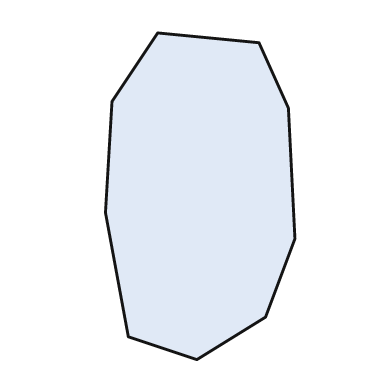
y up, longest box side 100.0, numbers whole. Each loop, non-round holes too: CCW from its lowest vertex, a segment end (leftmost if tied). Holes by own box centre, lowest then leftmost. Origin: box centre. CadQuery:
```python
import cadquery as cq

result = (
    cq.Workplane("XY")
    .moveTo(-1.0, -50.0)
    .lineTo(20.0, -37.0)
    .lineTo(29.0, -13.0)
    .lineTo(27.0, 27.0)
    .lineTo(18.0, 47.0)
    .lineTo(-13.0, 50.0)
    .lineTo(-27.0, 29.0)
    .lineTo(-29.0, -5.0)
    .lineTo(-22.0, -43.0)
    .close()
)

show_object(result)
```